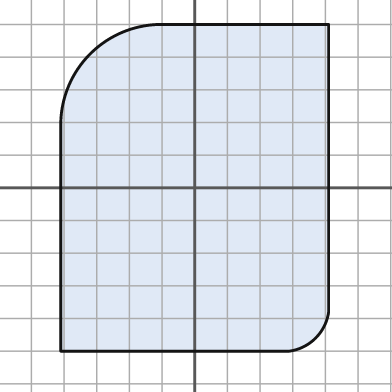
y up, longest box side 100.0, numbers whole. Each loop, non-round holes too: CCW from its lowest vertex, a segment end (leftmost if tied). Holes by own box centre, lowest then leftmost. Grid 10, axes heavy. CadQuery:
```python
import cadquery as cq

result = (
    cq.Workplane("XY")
    .moveTo(-41.0, -50.0)
    .lineTo(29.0, -50.0)
    .threePointArc((37.0, -46.0), (41.0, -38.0))
    .lineTo(41.0, 50.0)
    .lineTo(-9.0, 50.0)
    .threePointArc((-32.0, 41.0), (-41.0, 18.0))
    .close()
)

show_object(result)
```